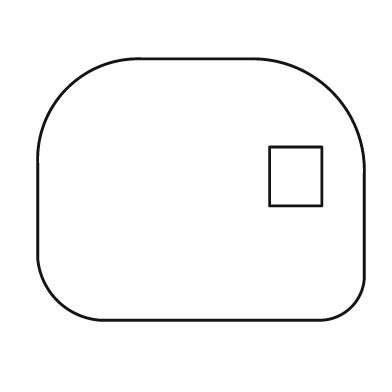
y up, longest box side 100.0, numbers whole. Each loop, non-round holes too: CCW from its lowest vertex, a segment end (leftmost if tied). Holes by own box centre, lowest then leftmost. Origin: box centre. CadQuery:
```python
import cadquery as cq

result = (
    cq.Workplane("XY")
    .moveTo(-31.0, -40.0)
    .lineTo(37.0, -40.0)
    .threePointArc((46.0, -36.0), (50.0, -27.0))
    .lineTo(50.0, 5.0)
    .threePointArc((40.0, 30.0), (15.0, 40.0))
    .lineTo(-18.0, 40.0)
    .threePointArc((-41.0, 31.0), (-50.0, 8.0))
    .lineTo(-50.0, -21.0)
    .threePointArc((-44.0, -34.0), (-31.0, -40.0))
    .close()
    .moveTo(21.0, -5.0)
    .lineTo(37.0, -5.0)
    .lineTo(37.0, 13.0)
    .lineTo(21.0, 13.0)
    .close()
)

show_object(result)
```